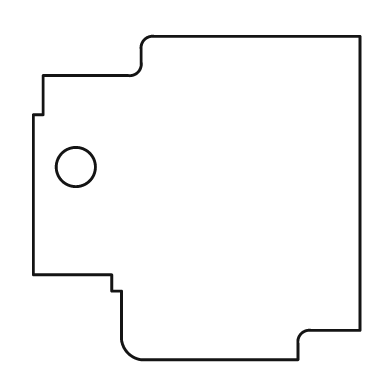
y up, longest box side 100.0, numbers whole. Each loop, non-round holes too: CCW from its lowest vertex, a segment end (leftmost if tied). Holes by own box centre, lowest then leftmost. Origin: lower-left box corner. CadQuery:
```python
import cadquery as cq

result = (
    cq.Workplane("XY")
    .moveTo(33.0, 0.0)
    .lineTo(81.0, 0.0)
    .lineTo(81.0, 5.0)
    .threePointArc((82.0, 8.0), (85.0, 9.0))
    .lineTo(100.0, 9.0)
    .lineTo(100.0, 99.0)
    .lineTo(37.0, 99.0)
    .threePointArc((34.0, 98.0), (33.0, 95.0))
    .lineTo(33.0, 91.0)
    .threePointArc((32.0, 88.0), (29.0, 87.0))
    .lineTo(3.0, 87.0)
    .lineTo(3.0, 75.0)
    .lineTo(0.0, 75.0)
    .lineTo(0.0, 26.0)
    .lineTo(24.0, 26.0)
    .lineTo(24.0, 21.0)
    .lineTo(27.0, 21.0)
    .lineTo(27.0, 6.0)
    .threePointArc((29.0, 2.0), (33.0, 0.0))
    .close()
    .moveTo(13.0, 59.0)
    .circle(6.0)
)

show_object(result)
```